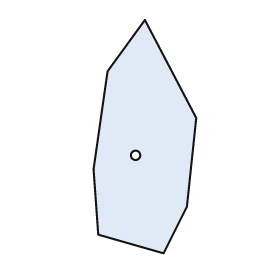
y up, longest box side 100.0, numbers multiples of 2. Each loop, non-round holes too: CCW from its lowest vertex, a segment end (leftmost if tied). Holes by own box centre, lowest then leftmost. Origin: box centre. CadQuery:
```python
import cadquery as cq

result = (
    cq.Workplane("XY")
    .moveTo(8.0, -50.0)
    .lineTo(18.0, -30.0)
    .lineTo(22.0, 8.0)
    .lineTo(0.0, 50.0)
    .lineTo(-16.0, 28.0)
    .lineTo(-22.0, -14.0)
    .lineTo(-20.0, -42.0)
    .close()
    .moveTo(-4.0, -8.0)
    .circle(2.0)
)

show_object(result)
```